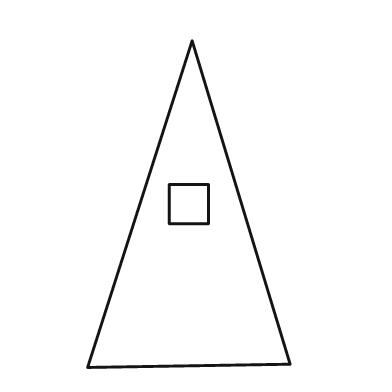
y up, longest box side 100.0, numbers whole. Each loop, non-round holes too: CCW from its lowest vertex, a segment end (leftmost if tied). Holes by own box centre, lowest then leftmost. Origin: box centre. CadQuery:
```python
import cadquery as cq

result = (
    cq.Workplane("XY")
    .moveTo(-31.0, -50.0)
    .lineTo(31.0, -49.0)
    .lineTo(1.0, 50.0)
    .close()
    .moveTo(-6.0, -6.0)
    .lineTo(6.0, -6.0)
    .lineTo(6.0, 6.0)
    .lineTo(-6.0, 6.0)
    .close()
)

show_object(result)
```